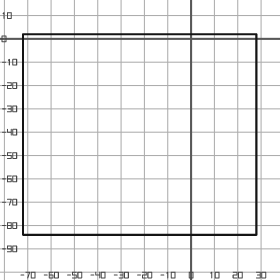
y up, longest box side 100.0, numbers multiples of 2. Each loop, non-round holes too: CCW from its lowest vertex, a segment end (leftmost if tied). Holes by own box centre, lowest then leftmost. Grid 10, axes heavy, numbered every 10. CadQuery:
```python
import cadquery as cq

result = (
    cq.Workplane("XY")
    .moveTo(-72.0, -84.0)
    .lineTo(28.0, -84.0)
    .lineTo(28.0, 2.0)
    .lineTo(-72.0, 2.0)
    .close()
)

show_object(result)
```